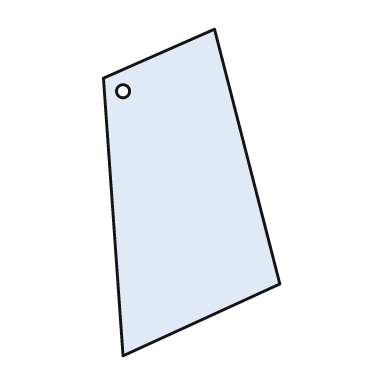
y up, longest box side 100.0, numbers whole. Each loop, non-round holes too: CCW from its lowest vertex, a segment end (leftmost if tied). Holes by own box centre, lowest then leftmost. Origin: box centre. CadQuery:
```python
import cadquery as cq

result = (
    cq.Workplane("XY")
    .moveTo(-21.0, -50.0)
    .lineTo(27.0, -28.0)
    .lineTo(7.0, 50.0)
    .lineTo(-27.0, 35.0)
    .close()
    .moveTo(-21.0, 31.0)
    .circle(2.0)
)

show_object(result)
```